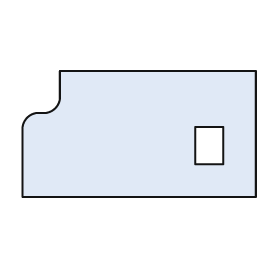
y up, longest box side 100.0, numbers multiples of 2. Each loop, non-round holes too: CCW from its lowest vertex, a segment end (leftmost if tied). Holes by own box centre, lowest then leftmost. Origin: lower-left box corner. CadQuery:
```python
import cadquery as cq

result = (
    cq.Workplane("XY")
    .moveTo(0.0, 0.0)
    .lineTo(100.0, 0.0)
    .lineTo(100.0, 54.0)
    .lineTo(16.0, 54.0)
    .lineTo(16.0, 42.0)
    .threePointArc((14.0, 38.0), (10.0, 36.0))
    .lineTo(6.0, 36.0)
    .threePointArc((2.0, 34.0), (0.0, 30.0))
    .close()
    .moveTo(74.0, 14.0)
    .lineTo(86.0, 14.0)
    .lineTo(86.0, 30.0)
    .lineTo(74.0, 30.0)
    .close()
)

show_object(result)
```